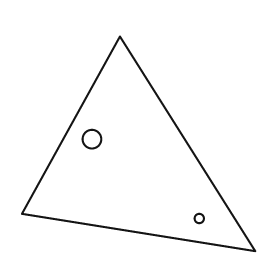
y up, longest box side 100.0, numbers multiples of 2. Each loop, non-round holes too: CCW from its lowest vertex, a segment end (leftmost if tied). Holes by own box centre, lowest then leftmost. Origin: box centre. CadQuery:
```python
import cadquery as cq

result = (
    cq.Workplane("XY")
    .moveTo(50.0, -46.0)
    .lineTo(-8.0, 46.0)
    .lineTo(-50.0, -30.0)
    .close()
    .moveTo(26.0, -32.0)
    .circle(2.0)
    .moveTo(-20.0, 2.0)
    .circle(4.0)
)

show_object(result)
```